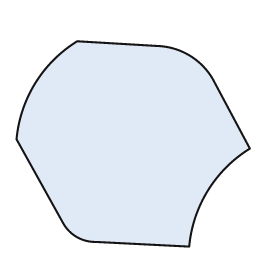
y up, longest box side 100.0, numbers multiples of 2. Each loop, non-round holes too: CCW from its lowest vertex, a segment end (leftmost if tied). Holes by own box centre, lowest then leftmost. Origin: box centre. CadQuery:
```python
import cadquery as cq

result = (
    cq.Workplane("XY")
    .moveTo(24.0, -44.0)
    .threePointArc((32.0, -20.0), (50.0, -2.0))
    .lineTo(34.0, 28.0)
    .threePointArc((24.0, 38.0), (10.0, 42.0))
    .lineTo(-24.0, 44.0)
    .threePointArc((-42.0, 26.0), (-50.0, 2.0))
    .lineTo(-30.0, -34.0)
    .threePointArc((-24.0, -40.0), (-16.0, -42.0))
    .close()
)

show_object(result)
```